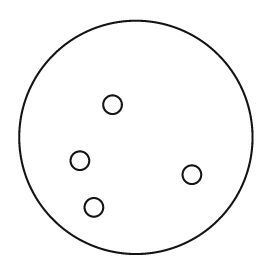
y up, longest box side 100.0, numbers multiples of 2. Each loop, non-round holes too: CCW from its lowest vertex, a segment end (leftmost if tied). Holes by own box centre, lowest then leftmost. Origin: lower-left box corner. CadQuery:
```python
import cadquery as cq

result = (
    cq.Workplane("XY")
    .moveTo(50.0, 50.0)
    .circle(50.0)
    .moveTo(32.0, 20.0)
    .circle(4.0)
    .moveTo(74.0, 34.0)
    .circle(4.0)
    .moveTo(26.0, 40.0)
    .circle(4.0)
    .moveTo(40.0, 64.0)
    .circle(4.0)
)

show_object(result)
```